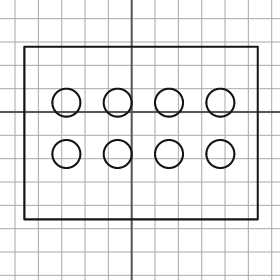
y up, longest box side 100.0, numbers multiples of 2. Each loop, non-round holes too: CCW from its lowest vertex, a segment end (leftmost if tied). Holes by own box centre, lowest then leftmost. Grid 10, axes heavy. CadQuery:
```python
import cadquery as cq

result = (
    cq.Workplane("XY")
    .moveTo(-46.0, -46.0)
    .lineTo(54.0, -46.0)
    .lineTo(54.0, 28.0)
    .lineTo(-46.0, 28.0)
    .close()
    .moveTo(-28.0, -18.0)
    .circle(6.0)
    .moveTo(-6.0, -18.0)
    .circle(6.0)
    .moveTo(16.0, -18.0)
    .circle(6.0)
    .moveTo(38.0, -18.0)
    .circle(6.0)
    .moveTo(-28.0, 4.0)
    .circle(6.0)
    .moveTo(-6.0, 4.0)
    .circle(6.0)
    .moveTo(16.0, 4.0)
    .circle(6.0)
    .moveTo(38.0, 4.0)
    .circle(6.0)
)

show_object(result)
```